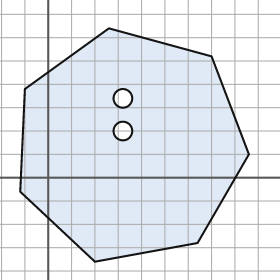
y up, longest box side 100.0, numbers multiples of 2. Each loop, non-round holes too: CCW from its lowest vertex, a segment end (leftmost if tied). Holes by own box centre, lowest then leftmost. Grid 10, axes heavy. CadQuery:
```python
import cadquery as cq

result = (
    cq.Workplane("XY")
    .moveTo(20.0, -36.0)
    .lineTo(64.0, -28.0)
    .lineTo(86.0, 10.0)
    .lineTo(70.0, 52.0)
    .lineTo(26.0, 64.0)
    .lineTo(-10.0, 38.0)
    .lineTo(-12.0, -6.0)
    .close()
    .moveTo(32.0, 20.0)
    .circle(4.0)
    .moveTo(32.0, 34.0)
    .circle(4.0)
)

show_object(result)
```